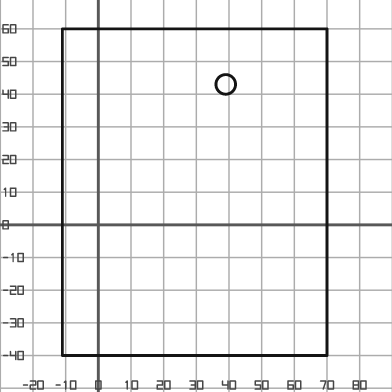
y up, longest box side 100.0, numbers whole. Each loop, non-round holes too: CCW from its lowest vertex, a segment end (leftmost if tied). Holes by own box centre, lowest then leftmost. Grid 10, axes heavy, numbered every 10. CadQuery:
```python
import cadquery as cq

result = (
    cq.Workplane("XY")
    .moveTo(-11.0, -40.0)
    .lineTo(70.0, -40.0)
    .lineTo(70.0, 60.0)
    .lineTo(-11.0, 60.0)
    .close()
    .moveTo(39.0, 43.0)
    .circle(3.0)
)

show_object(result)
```